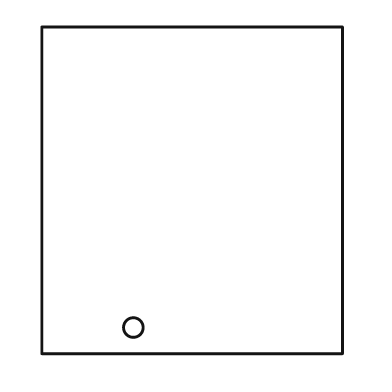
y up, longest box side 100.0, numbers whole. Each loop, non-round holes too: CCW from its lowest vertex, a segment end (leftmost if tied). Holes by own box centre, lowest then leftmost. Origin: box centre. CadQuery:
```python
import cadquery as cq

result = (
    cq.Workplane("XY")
    .moveTo(-46.0, -50.0)
    .lineTo(46.0, -50.0)
    .lineTo(46.0, 50.0)
    .lineTo(-46.0, 50.0)
    .close()
    .moveTo(-18.0, -42.0)
    .circle(3.0)
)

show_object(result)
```